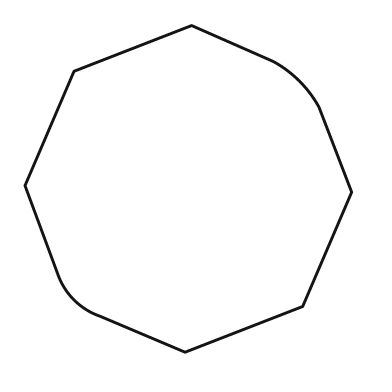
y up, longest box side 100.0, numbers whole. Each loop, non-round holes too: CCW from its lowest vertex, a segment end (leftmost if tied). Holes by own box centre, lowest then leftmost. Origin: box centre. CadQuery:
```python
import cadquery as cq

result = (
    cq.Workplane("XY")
    .moveTo(-1.0, -50.0)
    .lineTo(35.0, -36.0)
    .lineTo(50.0, -1.0)
    .lineTo(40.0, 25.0)
    .threePointArc((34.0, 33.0), (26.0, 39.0))
    .lineTo(1.0, 50.0)
    .lineTo(-35.0, 36.0)
    .lineTo(-50.0, 1.0)
    .lineTo(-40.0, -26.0)
    .threePointArc((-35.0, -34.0), (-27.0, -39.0))
    .close()
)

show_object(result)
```